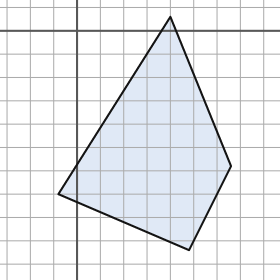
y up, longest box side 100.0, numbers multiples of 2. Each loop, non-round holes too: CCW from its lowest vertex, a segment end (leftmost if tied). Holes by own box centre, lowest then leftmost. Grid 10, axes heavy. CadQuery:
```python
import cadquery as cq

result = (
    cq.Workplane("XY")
    .moveTo(48.0, -94.0)
    .lineTo(66.0, -58.0)
    .lineTo(40.0, 6.0)
    .lineTo(-8.0, -70.0)
    .close()
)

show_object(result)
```